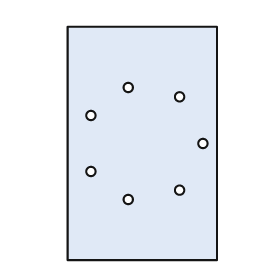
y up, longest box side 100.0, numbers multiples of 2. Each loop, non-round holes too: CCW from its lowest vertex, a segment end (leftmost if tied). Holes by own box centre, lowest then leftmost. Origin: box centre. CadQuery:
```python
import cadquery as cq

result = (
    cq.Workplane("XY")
    .moveTo(-32.0, -50.0)
    .lineTo(32.0, -50.0)
    .lineTo(32.0, 50.0)
    .lineTo(-32.0, 50.0)
    .close()
    .moveTo(-6.0, -24.0)
    .circle(2.0)
    .moveTo(16.0, -20.0)
    .circle(2.0)
    .moveTo(-22.0, -12.0)
    .circle(2.0)
    .moveTo(26.0, 0.0)
    .circle(2.0)
    .moveTo(-22.0, 12.0)
    .circle(2.0)
    .moveTo(16.0, 20.0)
    .circle(2.0)
    .moveTo(-6.0, 24.0)
    .circle(2.0)
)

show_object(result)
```